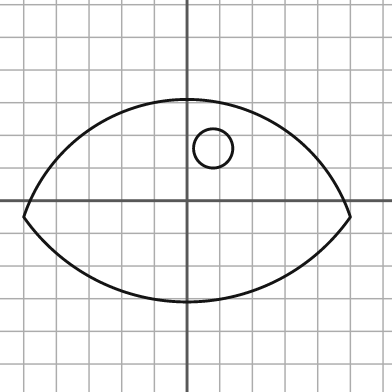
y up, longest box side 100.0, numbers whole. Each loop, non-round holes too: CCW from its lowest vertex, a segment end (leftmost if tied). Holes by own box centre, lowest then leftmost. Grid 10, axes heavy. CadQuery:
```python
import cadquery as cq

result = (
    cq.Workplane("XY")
    .moveTo(-50.0, -5.0)
    .threePointArc((0.0, -31.0), (50.0, -5.0))
    .threePointArc((0.0, 31.0), (-50.0, -5.0))
    .close()
    .moveTo(8.0, 16.0)
    .circle(6.0)
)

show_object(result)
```